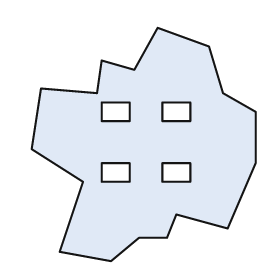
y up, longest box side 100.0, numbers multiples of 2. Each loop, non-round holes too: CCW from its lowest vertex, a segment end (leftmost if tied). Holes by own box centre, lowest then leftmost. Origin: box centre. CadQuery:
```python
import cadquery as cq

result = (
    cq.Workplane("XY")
    .moveTo(-14.0, -50.0)
    .lineTo(-2.0, -40.0)
    .lineTo(10.0, -40.0)
    .lineTo(14.0, -30.0)
    .lineTo(36.0, -36.0)
    .lineTo(48.0, -8.0)
    .lineTo(48.0, 14.0)
    .lineTo(34.0, 22.0)
    .lineTo(28.0, 42.0)
    .lineTo(6.0, 50.0)
    .lineTo(-4.0, 32.0)
    .lineTo(-18.0, 36.0)
    .lineTo(-20.0, 22.0)
    .lineTo(-44.0, 24.0)
    .lineTo(-48.0, -2.0)
    .lineTo(-26.0, -16.0)
    .lineTo(-36.0, -46.0)
    .close()
    .moveTo(-18.0, -16.0)
    .lineTo(-6.0, -16.0)
    .lineTo(-6.0, -8.0)
    .lineTo(-18.0, -8.0)
    .close()
    .moveTo(8.0, -16.0)
    .lineTo(20.0, -16.0)
    .lineTo(20.0, -8.0)
    .lineTo(8.0, -8.0)
    .close()
    .moveTo(-18.0, 10.0)
    .lineTo(-6.0, 10.0)
    .lineTo(-6.0, 18.0)
    .lineTo(-18.0, 18.0)
    .close()
    .moveTo(8.0, 10.0)
    .lineTo(20.0, 10.0)
    .lineTo(20.0, 18.0)
    .lineTo(8.0, 18.0)
    .close()
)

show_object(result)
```